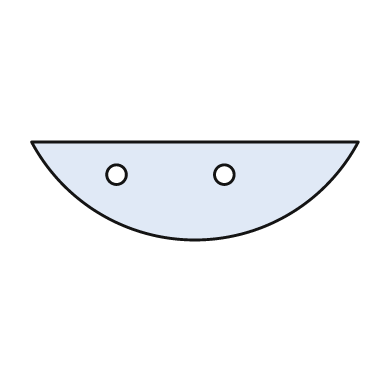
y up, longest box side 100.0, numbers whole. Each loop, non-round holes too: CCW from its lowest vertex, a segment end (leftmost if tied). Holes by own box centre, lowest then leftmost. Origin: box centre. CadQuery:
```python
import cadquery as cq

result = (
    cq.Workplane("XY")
    .moveTo(-50.0, 15.0)
    .threePointArc((0.0, -15.0), (50.0, 15.0))
    .close()
    .moveTo(-24.0, 5.0)
    .circle(3.0)
    .moveTo(9.0, 5.0)
    .circle(3.0)
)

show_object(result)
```